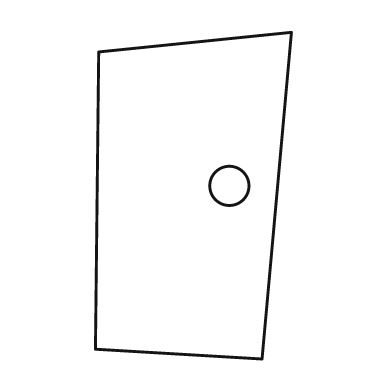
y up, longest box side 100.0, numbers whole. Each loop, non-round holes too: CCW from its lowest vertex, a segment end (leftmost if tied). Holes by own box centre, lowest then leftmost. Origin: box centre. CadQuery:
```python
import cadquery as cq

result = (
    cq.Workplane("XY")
    .moveTo(21.0, -50.0)
    .lineTo(30.0, 50.0)
    .lineTo(-29.0, 44.0)
    .lineTo(-30.0, -47.0)
    .close()
    .moveTo(11.0, 3.0)
    .circle(6.0)
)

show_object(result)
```